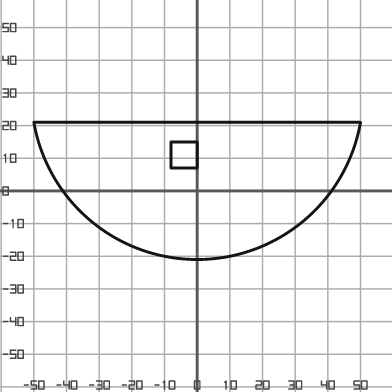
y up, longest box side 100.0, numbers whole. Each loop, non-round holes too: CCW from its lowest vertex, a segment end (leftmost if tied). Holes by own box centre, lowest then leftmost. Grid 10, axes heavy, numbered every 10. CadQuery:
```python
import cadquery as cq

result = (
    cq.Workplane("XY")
    .moveTo(-50.0, 21.0)
    .threePointArc((0.0, -21.0), (50.0, 21.0))
    .close()
    .moveTo(-8.0, 7.0)
    .lineTo(0.0, 7.0)
    .lineTo(0.0, 15.0)
    .lineTo(-8.0, 15.0)
    .close()
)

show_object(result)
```